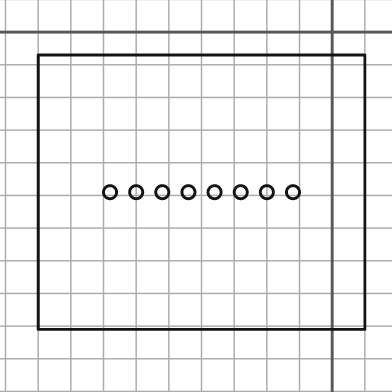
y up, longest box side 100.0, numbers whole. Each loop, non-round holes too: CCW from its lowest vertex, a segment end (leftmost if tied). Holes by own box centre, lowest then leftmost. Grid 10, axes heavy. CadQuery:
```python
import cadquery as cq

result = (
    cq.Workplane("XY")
    .moveTo(-90.0, -91.0)
    .lineTo(10.0, -91.0)
    .lineTo(10.0, -7.0)
    .lineTo(-90.0, -7.0)
    .close()
    .moveTo(-68.0, -49.0)
    .circle(2.0)
    .moveTo(-60.0, -49.0)
    .circle(2.0)
    .moveTo(-52.0, -49.0)
    .circle(2.0)
    .moveTo(-44.0, -49.0)
    .circle(2.0)
    .moveTo(-36.0, -49.0)
    .circle(2.0)
    .moveTo(-28.0, -49.0)
    .circle(2.0)
    .moveTo(-20.0, -49.0)
    .circle(2.0)
    .moveTo(-12.0, -49.0)
    .circle(2.0)
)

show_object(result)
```